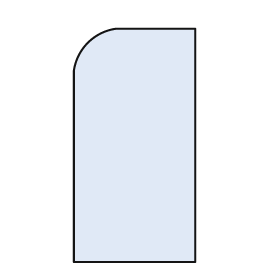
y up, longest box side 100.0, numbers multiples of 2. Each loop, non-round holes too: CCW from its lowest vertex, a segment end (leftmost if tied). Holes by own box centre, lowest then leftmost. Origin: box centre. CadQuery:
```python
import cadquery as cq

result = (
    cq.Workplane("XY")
    .moveTo(-26.0, -50.0)
    .lineTo(26.0, -50.0)
    .lineTo(26.0, 50.0)
    .lineTo(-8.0, 50.0)
    .threePointArc((-20.0, 44.0), (-26.0, 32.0))
    .close()
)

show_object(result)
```